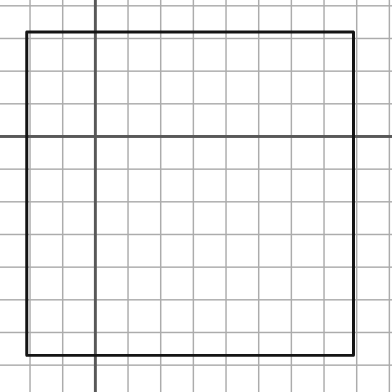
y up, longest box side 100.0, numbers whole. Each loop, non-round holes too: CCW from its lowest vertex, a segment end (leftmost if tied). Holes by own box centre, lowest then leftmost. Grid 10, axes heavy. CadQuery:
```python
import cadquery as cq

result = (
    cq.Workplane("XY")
    .moveTo(-21.0, -67.0)
    .lineTo(79.0, -67.0)
    .lineTo(79.0, 32.0)
    .lineTo(-21.0, 32.0)
    .close()
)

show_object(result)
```